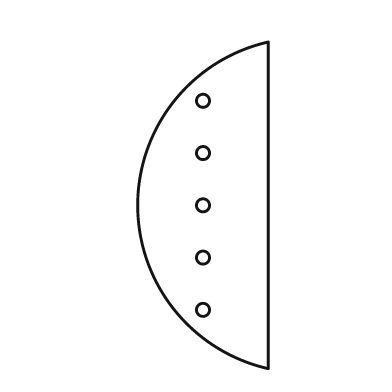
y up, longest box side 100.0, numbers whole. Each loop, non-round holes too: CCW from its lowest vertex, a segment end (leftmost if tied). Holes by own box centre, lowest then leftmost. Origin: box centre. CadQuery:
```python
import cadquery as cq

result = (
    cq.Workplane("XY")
    .moveTo(20.0, -50.0)
    .lineTo(20.0, 50.0)
    .threePointArc((-20.0, 0.0), (20.0, -50.0))
    .close()
    .moveTo(0.0, -32.0)
    .circle(2.0)
    .moveTo(0.0, -16.0)
    .circle(2.0)
    .moveTo(0.0, 0.0)
    .circle(2.0)
    .moveTo(0.0, 16.0)
    .circle(2.0)
    .moveTo(0.0, 32.0)
    .circle(2.0)
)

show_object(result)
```